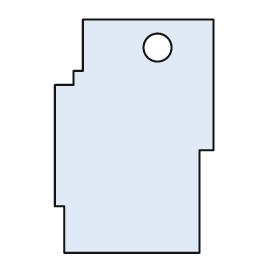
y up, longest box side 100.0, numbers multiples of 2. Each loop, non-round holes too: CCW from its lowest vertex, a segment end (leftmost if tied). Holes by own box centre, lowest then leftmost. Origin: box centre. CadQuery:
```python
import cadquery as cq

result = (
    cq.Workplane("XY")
    .moveTo(-30.0, -50.0)
    .lineTo(28.0, -50.0)
    .lineTo(28.0, -6.0)
    .lineTo(34.0, -6.0)
    .lineTo(34.0, 50.0)
    .lineTo(-22.0, 50.0)
    .lineTo(-22.0, 28.0)
    .lineTo(-26.0, 28.0)
    .lineTo(-26.0, 22.0)
    .lineTo(-34.0, 22.0)
    .lineTo(-34.0, -30.0)
    .lineTo(-30.0, -30.0)
    .close()
    .moveTo(10.0, 38.0)
    .circle(6.0)
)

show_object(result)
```